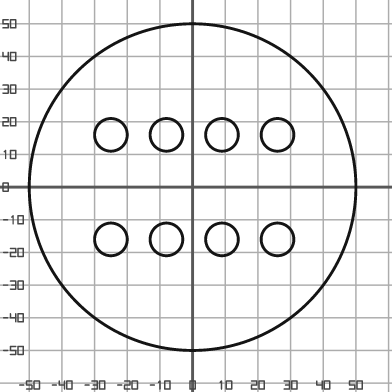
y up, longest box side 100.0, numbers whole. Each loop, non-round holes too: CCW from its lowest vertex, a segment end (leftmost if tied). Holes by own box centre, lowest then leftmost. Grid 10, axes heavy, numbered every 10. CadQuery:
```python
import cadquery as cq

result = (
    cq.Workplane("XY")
    .moveTo(0.0, 0.0)
    .circle(50.0)
    .moveTo(-25.0, -16.0)
    .circle(5.0)
    .moveTo(-8.0, -16.0)
    .circle(5.0)
    .moveTo(9.0, -16.0)
    .circle(5.0)
    .moveTo(26.0, -16.0)
    .circle(5.0)
    .moveTo(-25.0, 16.0)
    .circle(5.0)
    .moveTo(-8.0, 16.0)
    .circle(5.0)
    .moveTo(9.0, 16.0)
    .circle(5.0)
    .moveTo(26.0, 16.0)
    .circle(5.0)
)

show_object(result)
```